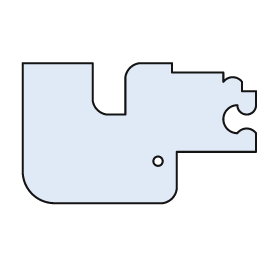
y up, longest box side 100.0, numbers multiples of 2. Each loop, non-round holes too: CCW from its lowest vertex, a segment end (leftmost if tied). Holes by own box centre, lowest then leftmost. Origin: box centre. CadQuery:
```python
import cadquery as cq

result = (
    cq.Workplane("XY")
    .moveTo(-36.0, -30.0)
    .lineTo(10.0, -30.0)
    .threePointArc((14.0, -28.0), (16.0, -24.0))
    .lineTo(16.0, -8.0)
    .lineTo(50.0, -8.0)
    .lineTo(50.0, 0.0)
    .threePointArc((46.0, 2.0), (42.0, 0.0))
    .threePointArc((36.0, 6.0), (42.0, 12.0))
    .threePointArc((46.0, 8.0), (50.0, 12.0))
    .lineTo(50.0, 18.0)
    .lineTo(44.0, 18.0)
    .lineTo(44.0, 22.0)
    .threePointArc((40.0, 24.0), (36.0, 22.0))
    .lineTo(36.0, 26.0)
    .lineTo(14.0, 26.0)
    .lineTo(14.0, 30.0)
    .lineTo(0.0, 30.0)
    .threePointArc((-4.0, 28.0), (-6.0, 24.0))
    .lineTo(-6.0, 8.0)
    .lineTo(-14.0, 8.0)
    .threePointArc((-18.0, 10.0), (-20.0, 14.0))
    .lineTo(-20.0, 30.0)
    .lineTo(-50.0, 30.0)
    .lineTo(-50.0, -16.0)
    .threePointArc((-46.0, -26.0), (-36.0, -30.0))
    .close()
    .moveTo(8.0, -12.0)
    .circle(2.0)
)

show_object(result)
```